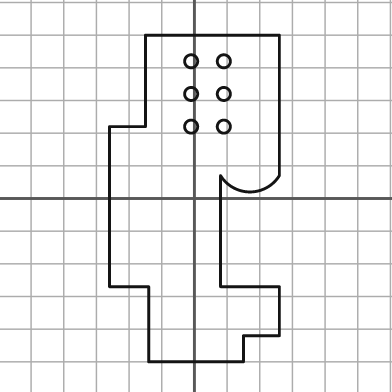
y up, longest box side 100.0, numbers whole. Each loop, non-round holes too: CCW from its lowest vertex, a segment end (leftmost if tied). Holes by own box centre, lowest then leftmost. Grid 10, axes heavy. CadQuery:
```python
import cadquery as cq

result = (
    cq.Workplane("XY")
    .moveTo(-14.0, -50.0)
    .lineTo(15.0, -50.0)
    .lineTo(15.0, -42.0)
    .lineTo(26.0, -42.0)
    .lineTo(26.0, -27.0)
    .lineTo(8.0, -27.0)
    .lineTo(8.0, 7.0)
    .threePointArc((17.0, 2.0), (26.0, 7.0))
    .lineTo(26.0, 50.0)
    .lineTo(-15.0, 50.0)
    .lineTo(-15.0, 22.0)
    .lineTo(-26.0, 22.0)
    .lineTo(-26.0, -27.0)
    .lineTo(-14.0, -27.0)
    .close()
    .moveTo(-1.0, 22.0)
    .circle(2.0)
    .moveTo(9.0, 22.0)
    .circle(2.0)
    .moveTo(-1.0, 32.0)
    .circle(2.0)
    .moveTo(9.0, 32.0)
    .circle(2.0)
    .moveTo(-1.0, 42.0)
    .circle(2.0)
    .moveTo(9.0, 42.0)
    .circle(2.0)
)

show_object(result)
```